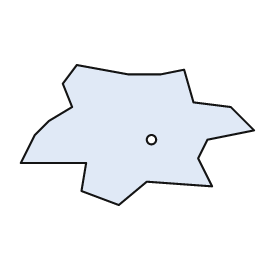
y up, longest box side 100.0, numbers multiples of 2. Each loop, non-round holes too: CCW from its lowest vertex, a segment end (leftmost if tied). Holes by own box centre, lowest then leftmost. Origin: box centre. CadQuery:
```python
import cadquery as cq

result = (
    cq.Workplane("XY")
    .moveTo(-8.0, -30.0)
    .lineTo(4.0, -20.0)
    .lineTo(32.0, -22.0)
    .lineTo(26.0, -10.0)
    .lineTo(30.0, -2.0)
    .lineTo(50.0, 2.0)
    .lineTo(40.0, 12.0)
    .lineTo(24.0, 14.0)
    .lineTo(20.0, 28.0)
    .lineTo(10.0, 26.0)
    .lineTo(-4.0, 26.0)
    .lineTo(-26.0, 30.0)
    .lineTo(-32.0, 22.0)
    .lineTo(-28.0, 12.0)
    .lineTo(-38.0, 6.0)
    .lineTo(-44.0, 0.0)
    .lineTo(-50.0, -12.0)
    .lineTo(-22.0, -12.0)
    .lineTo(-24.0, -24.0)
    .close()
    .moveTo(6.0, -2.0)
    .circle(2.0)
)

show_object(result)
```